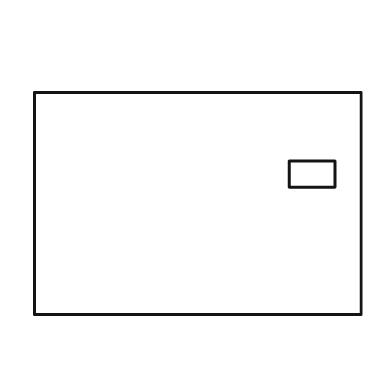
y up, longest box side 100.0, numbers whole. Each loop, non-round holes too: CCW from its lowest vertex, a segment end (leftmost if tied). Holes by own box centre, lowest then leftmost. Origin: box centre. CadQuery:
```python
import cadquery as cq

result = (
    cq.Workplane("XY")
    .moveTo(-50.0, -34.0)
    .lineTo(50.0, -34.0)
    .lineTo(50.0, 34.0)
    .lineTo(-50.0, 34.0)
    .close()
    .moveTo(28.0, 5.0)
    .lineTo(42.0, 5.0)
    .lineTo(42.0, 13.0)
    .lineTo(28.0, 13.0)
    .close()
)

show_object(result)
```